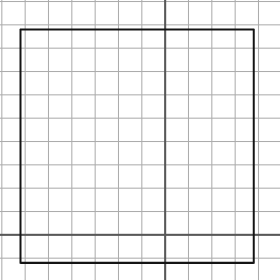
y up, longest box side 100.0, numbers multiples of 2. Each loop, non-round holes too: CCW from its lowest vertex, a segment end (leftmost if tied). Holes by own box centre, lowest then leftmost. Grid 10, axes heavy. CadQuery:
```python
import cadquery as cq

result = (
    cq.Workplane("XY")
    .moveTo(-62.0, -12.0)
    .lineTo(38.0, -12.0)
    .lineTo(38.0, 88.0)
    .lineTo(-62.0, 88.0)
    .close()
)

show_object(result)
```